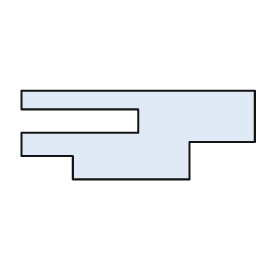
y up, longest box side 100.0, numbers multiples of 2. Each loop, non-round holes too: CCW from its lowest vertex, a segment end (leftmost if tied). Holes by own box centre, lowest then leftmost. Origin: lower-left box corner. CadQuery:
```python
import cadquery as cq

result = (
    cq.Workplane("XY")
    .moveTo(22.0, 0.0)
    .lineTo(72.0, 0.0)
    .lineTo(72.0, 16.0)
    .lineTo(100.0, 16.0)
    .lineTo(100.0, 38.0)
    .lineTo(0.0, 38.0)
    .lineTo(0.0, 30.0)
    .lineTo(50.0, 30.0)
    .lineTo(50.0, 20.0)
    .lineTo(0.0, 20.0)
    .lineTo(0.0, 10.0)
    .lineTo(22.0, 10.0)
    .close()
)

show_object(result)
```